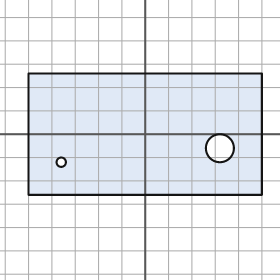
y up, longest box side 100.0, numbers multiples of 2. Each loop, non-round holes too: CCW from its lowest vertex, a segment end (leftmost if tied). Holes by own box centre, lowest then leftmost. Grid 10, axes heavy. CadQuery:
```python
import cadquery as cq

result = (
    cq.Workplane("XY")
    .moveTo(-50.0, -26.0)
    .lineTo(50.0, -26.0)
    .lineTo(50.0, 26.0)
    .lineTo(-50.0, 26.0)
    .close()
    .moveTo(-36.0, -12.0)
    .circle(2.0)
    .moveTo(32.0, -6.0)
    .circle(6.0)
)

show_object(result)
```